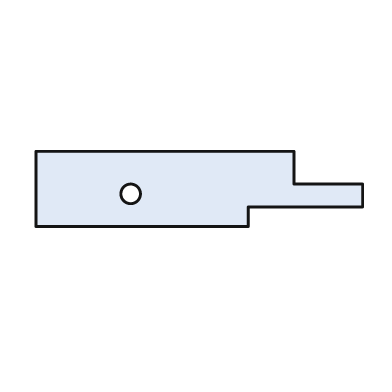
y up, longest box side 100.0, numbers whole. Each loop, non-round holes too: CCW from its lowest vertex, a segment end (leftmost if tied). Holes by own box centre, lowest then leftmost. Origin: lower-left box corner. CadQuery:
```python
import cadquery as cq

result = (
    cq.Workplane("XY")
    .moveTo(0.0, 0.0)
    .lineTo(65.0, 0.0)
    .lineTo(65.0, 6.0)
    .lineTo(100.0, 6.0)
    .lineTo(100.0, 13.0)
    .lineTo(79.0, 13.0)
    .lineTo(79.0, 23.0)
    .lineTo(0.0, 23.0)
    .close()
    .moveTo(29.0, 10.0)
    .circle(3.0)
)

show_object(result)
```